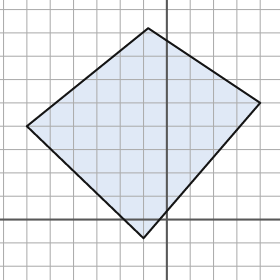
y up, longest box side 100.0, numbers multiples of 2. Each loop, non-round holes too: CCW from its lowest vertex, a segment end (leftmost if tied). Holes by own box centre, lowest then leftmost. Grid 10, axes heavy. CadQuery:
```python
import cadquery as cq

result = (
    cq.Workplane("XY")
    .moveTo(-10.0, -8.0)
    .lineTo(40.0, 50.0)
    .lineTo(-8.0, 82.0)
    .lineTo(-60.0, 40.0)
    .close()
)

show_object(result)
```